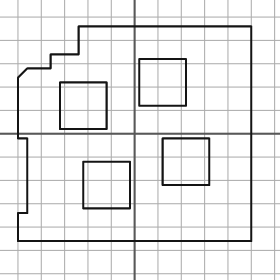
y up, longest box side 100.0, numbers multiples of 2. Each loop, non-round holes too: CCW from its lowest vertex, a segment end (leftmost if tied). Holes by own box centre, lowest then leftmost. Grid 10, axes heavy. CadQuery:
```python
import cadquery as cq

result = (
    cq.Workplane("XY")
    .moveTo(-50.0, -46.0)
    .lineTo(50.0, -46.0)
    .lineTo(50.0, 46.0)
    .lineTo(-24.0, 46.0)
    .lineTo(-24.0, 34.0)
    .lineTo(-36.0, 34.0)
    .lineTo(-36.0, 28.0)
    .lineTo(-46.0, 28.0)
    .lineTo(-50.0, 24.0)
    .lineTo(-50.0, -2.0)
    .lineTo(-46.0, -2.0)
    .lineTo(-46.0, -34.0)
    .lineTo(-50.0, -34.0)
    .close()
    .moveTo(-22.0, -32.0)
    .lineTo(-2.0, -32.0)
    .lineTo(-2.0, -12.0)
    .lineTo(-22.0, -12.0)
    .close()
    .moveTo(12.0, -22.0)
    .lineTo(32.0, -22.0)
    .lineTo(32.0, -2.0)
    .lineTo(12.0, -2.0)
    .close()
    .moveTo(-32.0, 2.0)
    .lineTo(-12.0, 2.0)
    .lineTo(-12.0, 22.0)
    .lineTo(-32.0, 22.0)
    .close()
    .moveTo(2.0, 12.0)
    .lineTo(22.0, 12.0)
    .lineTo(22.0, 32.0)
    .lineTo(2.0, 32.0)
    .close()
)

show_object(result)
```